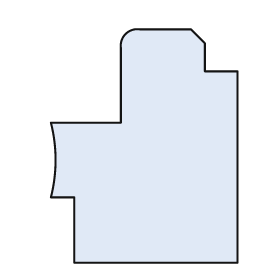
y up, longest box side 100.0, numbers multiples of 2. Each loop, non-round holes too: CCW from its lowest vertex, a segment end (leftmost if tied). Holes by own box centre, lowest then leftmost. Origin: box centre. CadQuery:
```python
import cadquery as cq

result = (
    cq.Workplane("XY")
    .moveTo(-30.0, -50.0)
    .lineTo(40.0, -50.0)
    .lineTo(40.0, 32.0)
    .lineTo(26.0, 32.0)
    .lineTo(26.0, 44.0)
    .lineTo(20.0, 50.0)
    .lineTo(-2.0, 50.0)
    .threePointArc((-8.0, 48.0), (-10.0, 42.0))
    .lineTo(-10.0, 10.0)
    .lineTo(-40.0, 10.0)
    .threePointArc((-38.0, -6.0), (-40.0, -22.0))
    .lineTo(-30.0, -22.0)
    .close()
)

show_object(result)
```